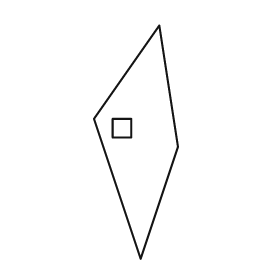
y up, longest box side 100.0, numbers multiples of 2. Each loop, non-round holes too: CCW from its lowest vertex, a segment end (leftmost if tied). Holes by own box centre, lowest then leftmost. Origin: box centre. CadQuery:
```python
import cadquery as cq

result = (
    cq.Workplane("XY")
    .moveTo(2.0, -50.0)
    .lineTo(18.0, -2.0)
    .lineTo(10.0, 50.0)
    .lineTo(-18.0, 10.0)
    .close()
    .moveTo(-10.0, 2.0)
    .lineTo(-2.0, 2.0)
    .lineTo(-2.0, 10.0)
    .lineTo(-10.0, 10.0)
    .close()
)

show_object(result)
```